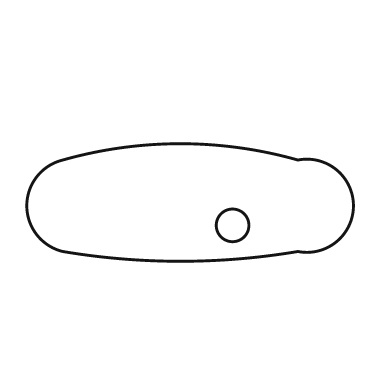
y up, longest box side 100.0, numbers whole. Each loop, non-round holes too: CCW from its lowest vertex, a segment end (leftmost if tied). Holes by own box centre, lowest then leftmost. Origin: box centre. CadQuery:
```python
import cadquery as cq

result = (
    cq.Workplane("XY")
    .moveTo(-39.0, -15.0)
    .threePointArc((-3.0, -18.0), (33.0, -15.0))
    .threePointArc((50.0, -1.0), (33.0, 13.0))
    .threePointArc((-3.0, 18.0), (-39.0, 13.0))
    .threePointArc((-50.0, -1.0), (-39.0, -15.0))
    .close()
    .moveTo(13.0, -7.0)
    .circle(5.0)
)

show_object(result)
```